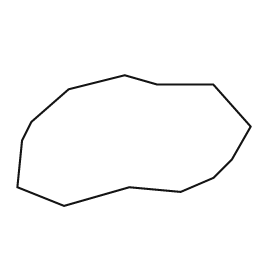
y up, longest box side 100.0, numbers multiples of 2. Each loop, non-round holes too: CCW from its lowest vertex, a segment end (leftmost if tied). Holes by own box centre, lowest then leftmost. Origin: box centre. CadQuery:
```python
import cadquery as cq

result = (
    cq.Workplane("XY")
    .moveTo(-30.0, -28.0)
    .lineTo(-2.0, -20.0)
    .lineTo(20.0, -22.0)
    .lineTo(34.0, -16.0)
    .lineTo(42.0, -8.0)
    .lineTo(50.0, 6.0)
    .lineTo(34.0, 24.0)
    .lineTo(10.0, 24.0)
    .lineTo(-4.0, 28.0)
    .lineTo(-28.0, 22.0)
    .lineTo(-44.0, 8.0)
    .lineTo(-48.0, 0.0)
    .lineTo(-50.0, -20.0)
    .close()
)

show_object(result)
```